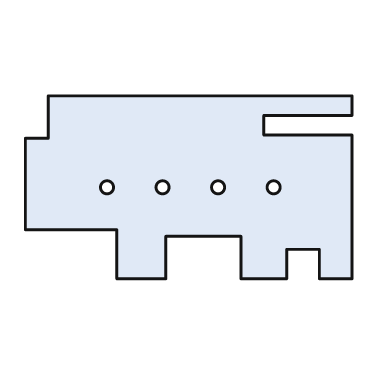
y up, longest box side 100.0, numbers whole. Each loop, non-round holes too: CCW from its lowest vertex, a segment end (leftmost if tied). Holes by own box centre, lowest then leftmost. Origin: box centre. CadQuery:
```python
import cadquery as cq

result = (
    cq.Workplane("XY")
    .moveTo(-22.0, -28.0)
    .lineTo(-7.0, -28.0)
    .lineTo(-7.0, -15.0)
    .lineTo(16.0, -15.0)
    .lineTo(16.0, -28.0)
    .lineTo(30.0, -28.0)
    .lineTo(30.0, -19.0)
    .lineTo(40.0, -19.0)
    .lineTo(40.0, -28.0)
    .lineTo(50.0, -28.0)
    .lineTo(50.0, 16.0)
    .lineTo(23.0, 16.0)
    .lineTo(23.0, 22.0)
    .lineTo(50.0, 22.0)
    .lineTo(50.0, 28.0)
    .lineTo(-43.0, 28.0)
    .lineTo(-43.0, 15.0)
    .lineTo(-50.0, 15.0)
    .lineTo(-50.0, -13.0)
    .lineTo(-22.0, -13.0)
    .close()
    .moveTo(-25.0, 0.0)
    .circle(2.0)
    .moveTo(-8.0, 0.0)
    .circle(2.0)
    .moveTo(9.0, 0.0)
    .circle(2.0)
    .moveTo(26.0, 0.0)
    .circle(2.0)
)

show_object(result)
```